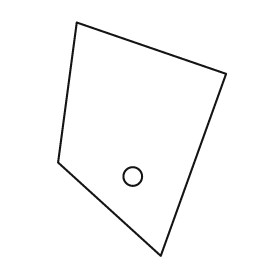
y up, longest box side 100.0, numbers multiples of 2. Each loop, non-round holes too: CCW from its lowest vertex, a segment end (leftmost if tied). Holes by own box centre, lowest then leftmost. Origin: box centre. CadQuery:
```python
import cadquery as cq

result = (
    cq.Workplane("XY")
    .moveTo(8.0, -50.0)
    .lineTo(36.0, 28.0)
    .lineTo(-28.0, 50.0)
    .lineTo(-36.0, -10.0)
    .close()
    .moveTo(-4.0, -16.0)
    .circle(4.0)
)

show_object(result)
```